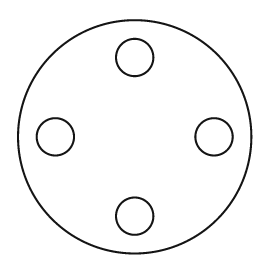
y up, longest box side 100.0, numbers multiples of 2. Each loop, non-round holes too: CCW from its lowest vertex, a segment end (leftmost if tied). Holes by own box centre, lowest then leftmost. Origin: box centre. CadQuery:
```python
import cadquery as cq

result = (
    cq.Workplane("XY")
    .moveTo(0.0, 0.0)
    .circle(50.0)
    .moveTo(0.0, -34.0)
    .circle(8.0)
    .moveTo(-34.0, 0.0)
    .circle(8.0)
    .moveTo(34.0, 0.0)
    .circle(8.0)
    .moveTo(0.0, 34.0)
    .circle(8.0)
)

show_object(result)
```